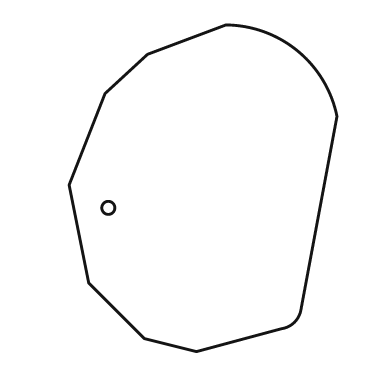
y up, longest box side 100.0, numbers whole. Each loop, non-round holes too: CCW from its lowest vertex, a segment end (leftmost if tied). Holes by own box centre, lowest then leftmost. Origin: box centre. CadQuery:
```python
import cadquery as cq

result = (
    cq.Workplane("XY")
    .moveTo(-2.0, -50.0)
    .lineTo(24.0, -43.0)
    .threePointArc((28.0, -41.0), (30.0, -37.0))
    .lineTo(41.0, 22.0)
    .threePointArc((29.0, 42.0), (7.0, 50.0))
    .lineTo(-17.0, 41.0)
    .lineTo(-30.0, 29.0)
    .lineTo(-41.0, 1.0)
    .lineTo(-35.0, -29.0)
    .lineTo(-18.0, -46.0)
    .close()
    .moveTo(-29.0, -6.0)
    .circle(2.0)
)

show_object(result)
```